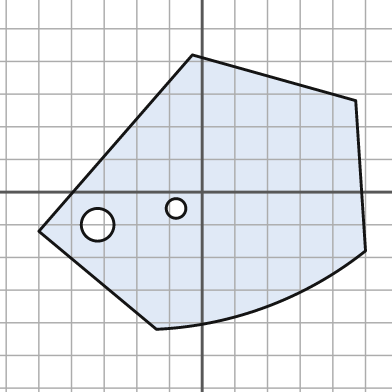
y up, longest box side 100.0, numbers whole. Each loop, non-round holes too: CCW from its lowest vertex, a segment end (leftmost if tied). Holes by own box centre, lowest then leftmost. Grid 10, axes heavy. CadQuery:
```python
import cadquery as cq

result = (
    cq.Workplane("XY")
    .moveTo(-14.0, -42.0)
    .threePointArc((20.0, -35.0), (50.0, -18.0))
    .lineTo(47.0, 28.0)
    .lineTo(-3.0, 42.0)
    .lineTo(-50.0, -12.0)
    .close()
    .moveTo(-32.0, -10.0)
    .circle(5.0)
    .moveTo(-8.0, -5.0)
    .circle(3.0)
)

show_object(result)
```